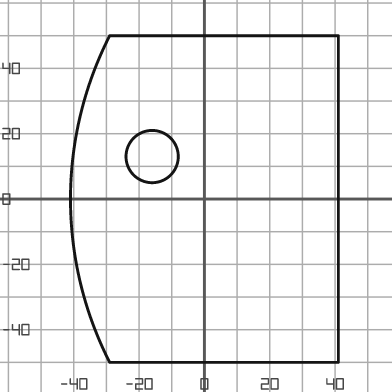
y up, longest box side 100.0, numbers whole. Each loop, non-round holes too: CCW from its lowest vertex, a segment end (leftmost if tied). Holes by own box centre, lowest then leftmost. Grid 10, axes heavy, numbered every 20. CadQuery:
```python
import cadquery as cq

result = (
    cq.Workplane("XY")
    .moveTo(-29.0, -50.0)
    .lineTo(41.0, -50.0)
    .lineTo(41.0, 50.0)
    .lineTo(-29.0, 50.0)
    .threePointArc((-41.0, 0.0), (-29.0, -50.0))
    .close()
    .moveTo(-16.0, 13.0)
    .circle(8.0)
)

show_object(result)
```